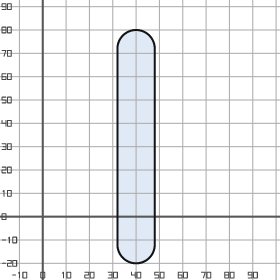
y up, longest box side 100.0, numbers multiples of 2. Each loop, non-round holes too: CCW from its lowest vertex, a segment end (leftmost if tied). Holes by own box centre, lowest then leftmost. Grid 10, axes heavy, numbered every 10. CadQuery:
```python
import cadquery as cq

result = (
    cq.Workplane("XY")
    .moveTo(32.0, -12.0)
    .threePointArc((40.0, -20.0), (48.0, -12.0))
    .lineTo(48.0, 72.0)
    .threePointArc((40.0, 80.0), (32.0, 72.0))
    .close()
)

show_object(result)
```